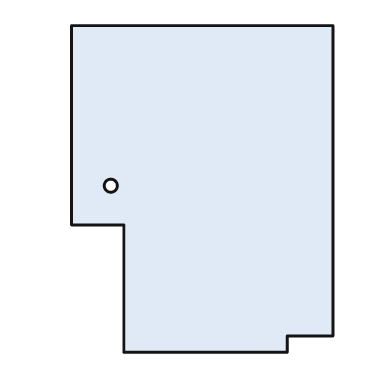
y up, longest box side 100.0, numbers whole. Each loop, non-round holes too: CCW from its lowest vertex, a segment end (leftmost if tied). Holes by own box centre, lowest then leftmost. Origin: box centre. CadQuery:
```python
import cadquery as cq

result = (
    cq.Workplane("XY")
    .moveTo(-24.0, -50.0)
    .lineTo(26.0, -50.0)
    .lineTo(26.0, -45.0)
    .lineTo(40.0, -45.0)
    .lineTo(40.0, 50.0)
    .lineTo(-40.0, 50.0)
    .lineTo(-40.0, -11.0)
    .lineTo(-24.0, -11.0)
    .close()
    .moveTo(-28.0, 1.0)
    .circle(2.0)
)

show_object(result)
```